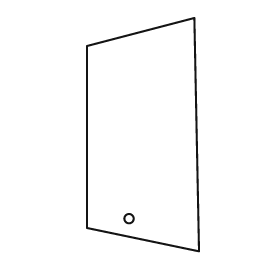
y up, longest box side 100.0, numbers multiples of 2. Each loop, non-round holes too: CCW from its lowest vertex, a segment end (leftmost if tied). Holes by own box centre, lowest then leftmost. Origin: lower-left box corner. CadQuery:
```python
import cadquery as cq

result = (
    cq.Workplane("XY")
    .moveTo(48.0, 0.0)
    .lineTo(46.0, 100.0)
    .lineTo(0.0, 88.0)
    .lineTo(0.0, 10.0)
    .close()
    .moveTo(18.0, 14.0)
    .circle(2.0)
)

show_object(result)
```